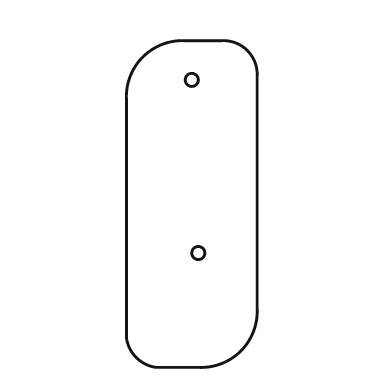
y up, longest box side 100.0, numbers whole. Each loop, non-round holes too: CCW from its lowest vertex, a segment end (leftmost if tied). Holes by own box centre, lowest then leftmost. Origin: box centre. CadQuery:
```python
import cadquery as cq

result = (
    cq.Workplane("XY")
    .moveTo(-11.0, -50.0)
    .lineTo(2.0, -50.0)
    .threePointArc((15.0, -45.0), (20.0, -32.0))
    .lineTo(20.0, 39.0)
    .threePointArc((17.0, 47.0), (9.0, 50.0))
    .lineTo(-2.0, 50.0)
    .threePointArc((-15.0, 45.0), (-20.0, 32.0))
    .lineTo(-20.0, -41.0)
    .threePointArc((-17.0, -47.0), (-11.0, -50.0))
    .close()
    .moveTo(2.0, -15.0)
    .circle(2.0)
    .moveTo(0.0, 38.0)
    .circle(2.0)
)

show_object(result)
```